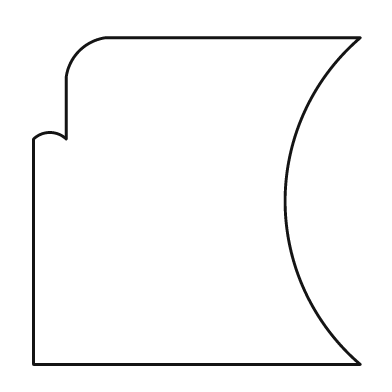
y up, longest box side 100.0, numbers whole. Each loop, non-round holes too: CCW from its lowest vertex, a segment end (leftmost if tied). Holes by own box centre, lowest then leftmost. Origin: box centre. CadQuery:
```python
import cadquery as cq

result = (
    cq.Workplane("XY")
    .moveTo(-50.0, -50.0)
    .lineTo(50.0, -50.0)
    .threePointArc((27.0, 0.0), (50.0, 50.0))
    .lineTo(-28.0, 50.0)
    .threePointArc((-36.0, 46.0), (-40.0, 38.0))
    .lineTo(-40.0, 19.0)
    .threePointArc((-45.0, 21.0), (-50.0, 19.0))
    .close()
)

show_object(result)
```